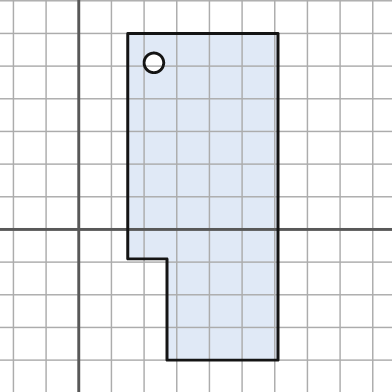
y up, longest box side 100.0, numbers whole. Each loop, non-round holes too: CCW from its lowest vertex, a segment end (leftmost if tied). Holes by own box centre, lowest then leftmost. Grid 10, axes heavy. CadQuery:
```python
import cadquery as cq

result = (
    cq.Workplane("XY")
    .moveTo(27.0, -40.0)
    .lineTo(61.0, -40.0)
    .lineTo(61.0, 60.0)
    .lineTo(15.0, 60.0)
    .lineTo(15.0, -9.0)
    .lineTo(27.0, -9.0)
    .close()
    .moveTo(23.0, 51.0)
    .circle(3.0)
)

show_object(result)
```